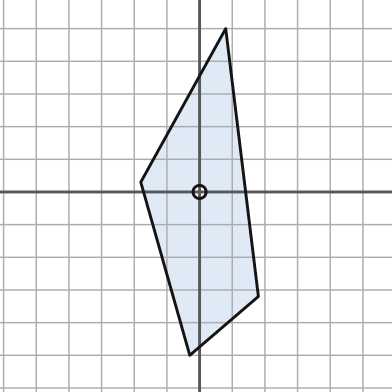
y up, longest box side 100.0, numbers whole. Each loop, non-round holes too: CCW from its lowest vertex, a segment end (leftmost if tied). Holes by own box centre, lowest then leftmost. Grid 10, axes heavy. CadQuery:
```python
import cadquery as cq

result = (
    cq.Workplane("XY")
    .moveTo(-3.0, -50.0)
    .lineTo(18.0, -32.0)
    .lineTo(8.0, 50.0)
    .lineTo(-18.0, 3.0)
    .close()
    .moveTo(0.0, 0.0)
    .circle(2.0)
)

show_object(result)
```